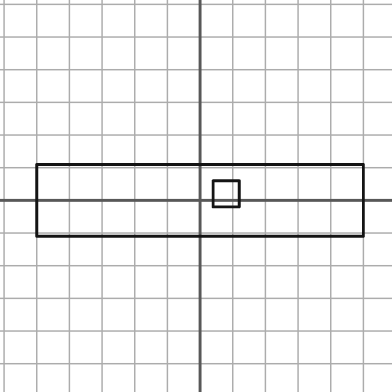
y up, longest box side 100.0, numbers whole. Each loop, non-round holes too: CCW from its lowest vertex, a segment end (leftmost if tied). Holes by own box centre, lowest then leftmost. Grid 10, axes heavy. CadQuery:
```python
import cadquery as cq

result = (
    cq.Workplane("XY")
    .moveTo(-50.0, -11.0)
    .lineTo(50.0, -11.0)
    .lineTo(50.0, 11.0)
    .lineTo(-50.0, 11.0)
    .close()
    .moveTo(4.0, -2.0)
    .lineTo(12.0, -2.0)
    .lineTo(12.0, 6.0)
    .lineTo(4.0, 6.0)
    .close()
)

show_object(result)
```